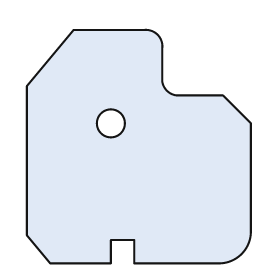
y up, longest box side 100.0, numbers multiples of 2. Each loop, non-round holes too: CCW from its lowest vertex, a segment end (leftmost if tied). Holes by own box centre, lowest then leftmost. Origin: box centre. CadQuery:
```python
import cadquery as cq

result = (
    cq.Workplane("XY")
    .moveTo(-38.0, -50.0)
    .lineTo(-12.0, -50.0)
    .lineTo(-12.0, -40.0)
    .lineTo(-2.0, -40.0)
    .lineTo(-2.0, -50.0)
    .lineTo(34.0, -50.0)
    .threePointArc((44.0, -46.0), (48.0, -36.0))
    .lineTo(48.0, 10.0)
    .lineTo(36.0, 22.0)
    .lineTo(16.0, 22.0)
    .threePointArc((12.0, 24.0), (10.0, 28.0))
    .lineTo(10.0, 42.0)
    .threePointArc((8.0, 48.0), (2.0, 50.0))
    .lineTo(-28.0, 50.0)
    .lineTo(-48.0, 26.0)
    .lineTo(-48.0, -38.0)
    .close()
    .moveTo(-12.0, 10.0)
    .circle(6.0)
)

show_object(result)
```